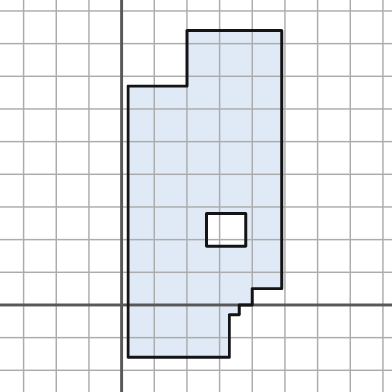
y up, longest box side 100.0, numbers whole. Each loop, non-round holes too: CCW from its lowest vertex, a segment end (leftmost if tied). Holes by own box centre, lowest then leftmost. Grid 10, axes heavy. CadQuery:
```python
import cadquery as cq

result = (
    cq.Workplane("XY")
    .moveTo(2.0, -16.0)
    .lineTo(33.0, -16.0)
    .lineTo(33.0, -3.0)
    .lineTo(36.0, -3.0)
    .lineTo(36.0, 0.0)
    .lineTo(40.0, 0.0)
    .lineTo(40.0, 5.0)
    .lineTo(49.0, 5.0)
    .lineTo(49.0, 84.0)
    .lineTo(20.0, 84.0)
    .lineTo(20.0, 67.0)
    .lineTo(2.0, 67.0)
    .close()
    .moveTo(26.0, 18.0)
    .lineTo(38.0, 18.0)
    .lineTo(38.0, 28.0)
    .lineTo(26.0, 28.0)
    .close()
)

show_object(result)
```